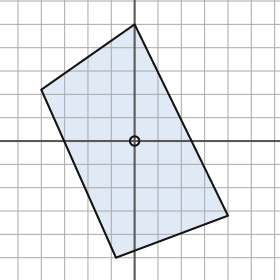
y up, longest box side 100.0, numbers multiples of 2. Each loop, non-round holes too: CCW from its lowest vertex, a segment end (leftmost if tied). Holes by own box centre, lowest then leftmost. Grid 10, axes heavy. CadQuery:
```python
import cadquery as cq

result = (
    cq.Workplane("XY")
    .moveTo(-8.0, -50.0)
    .lineTo(40.0, -32.0)
    .lineTo(0.0, 50.0)
    .lineTo(-40.0, 22.0)
    .close()
    .moveTo(0.0, 0.0)
    .circle(2.0)
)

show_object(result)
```